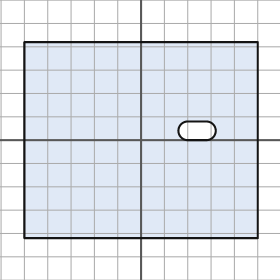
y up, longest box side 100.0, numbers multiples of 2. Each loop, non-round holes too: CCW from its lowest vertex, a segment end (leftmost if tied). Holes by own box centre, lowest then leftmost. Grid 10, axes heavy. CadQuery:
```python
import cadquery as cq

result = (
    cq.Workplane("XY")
    .moveTo(-50.0, -42.0)
    .lineTo(50.0, -42.0)
    .lineTo(50.0, 42.0)
    .lineTo(-50.0, 42.0)
    .close()
    .moveTo(20.0, 0.0)
    .lineTo(28.0, 0.0)
    .threePointArc((32.0, 4.0), (28.0, 8.0))
    .lineTo(20.0, 8.0)
    .threePointArc((16.0, 4.0), (20.0, 0.0))
    .close()
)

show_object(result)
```